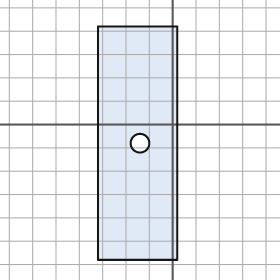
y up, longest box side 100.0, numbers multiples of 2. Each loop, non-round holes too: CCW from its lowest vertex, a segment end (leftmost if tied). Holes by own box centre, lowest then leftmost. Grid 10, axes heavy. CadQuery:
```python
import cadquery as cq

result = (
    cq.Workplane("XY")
    .moveTo(-32.0, -58.0)
    .lineTo(2.0, -58.0)
    .lineTo(2.0, 42.0)
    .lineTo(-32.0, 42.0)
    .close()
    .moveTo(-14.0, -8.0)
    .circle(4.0)
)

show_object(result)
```